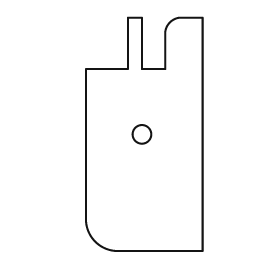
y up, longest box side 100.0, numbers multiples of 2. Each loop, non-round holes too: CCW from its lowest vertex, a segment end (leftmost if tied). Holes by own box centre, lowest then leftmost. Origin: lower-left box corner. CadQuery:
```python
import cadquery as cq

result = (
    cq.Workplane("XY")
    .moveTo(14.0, 0.0)
    .lineTo(50.0, 0.0)
    .lineTo(50.0, 100.0)
    .lineTo(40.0, 100.0)
    .threePointArc((36.0, 98.0), (34.0, 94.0))
    .lineTo(34.0, 78.0)
    .lineTo(24.0, 78.0)
    .lineTo(24.0, 100.0)
    .lineTo(18.0, 100.0)
    .lineTo(18.0, 78.0)
    .lineTo(0.0, 78.0)
    .lineTo(0.0, 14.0)
    .threePointArc((4.0, 4.0), (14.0, 0.0))
    .close()
    .moveTo(24.0, 50.0)
    .circle(4.0)
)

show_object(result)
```